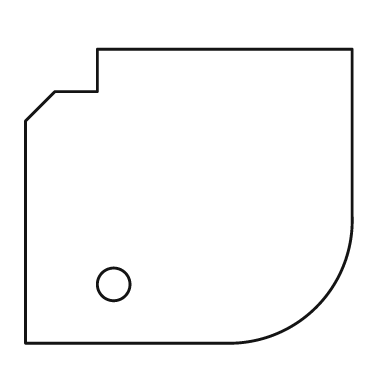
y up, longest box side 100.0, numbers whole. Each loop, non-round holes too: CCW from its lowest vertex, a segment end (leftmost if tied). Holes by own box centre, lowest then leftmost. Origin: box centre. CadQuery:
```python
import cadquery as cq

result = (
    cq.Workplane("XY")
    .moveTo(-50.0, -45.0)
    .lineTo(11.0, -45.0)
    .threePointArc((39.0, -34.0), (50.0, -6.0))
    .lineTo(50.0, 45.0)
    .lineTo(-28.0, 45.0)
    .lineTo(-28.0, 32.0)
    .lineTo(-41.0, 32.0)
    .lineTo(-50.0, 23.0)
    .close()
    .moveTo(-23.0, -27.0)
    .circle(5.0)
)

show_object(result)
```